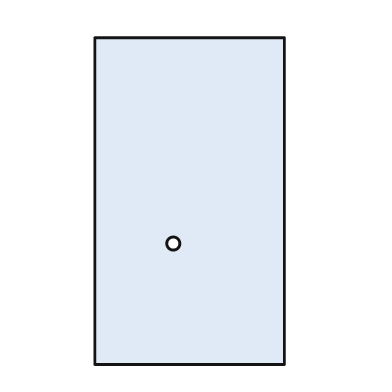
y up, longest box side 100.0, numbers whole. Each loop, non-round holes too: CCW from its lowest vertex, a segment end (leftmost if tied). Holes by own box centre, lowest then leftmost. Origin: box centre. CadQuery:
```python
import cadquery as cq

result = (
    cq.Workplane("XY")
    .moveTo(-29.0, -50.0)
    .lineTo(29.0, -50.0)
    .lineTo(29.0, 50.0)
    .lineTo(-29.0, 50.0)
    .close()
    .moveTo(-5.0, -13.0)
    .circle(2.0)
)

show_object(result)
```